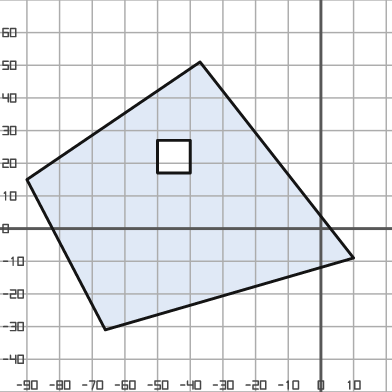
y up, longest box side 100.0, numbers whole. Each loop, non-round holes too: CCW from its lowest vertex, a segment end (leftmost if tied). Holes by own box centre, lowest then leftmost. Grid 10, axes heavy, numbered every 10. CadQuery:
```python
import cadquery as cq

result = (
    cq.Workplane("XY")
    .moveTo(-66.0, -31.0)
    .lineTo(10.0, -9.0)
    .lineTo(-37.0, 51.0)
    .lineTo(-90.0, 15.0)
    .close()
    .moveTo(-50.0, 17.0)
    .lineTo(-40.0, 17.0)
    .lineTo(-40.0, 27.0)
    .lineTo(-50.0, 27.0)
    .close()
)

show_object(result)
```